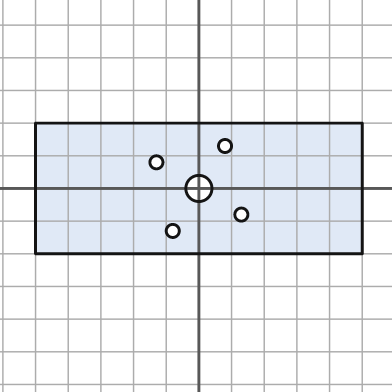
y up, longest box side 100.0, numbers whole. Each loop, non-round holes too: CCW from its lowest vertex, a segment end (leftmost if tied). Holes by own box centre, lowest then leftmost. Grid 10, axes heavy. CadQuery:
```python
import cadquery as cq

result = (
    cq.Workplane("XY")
    .moveTo(-50.0, -20.0)
    .lineTo(50.0, -20.0)
    .lineTo(50.0, 20.0)
    .lineTo(-50.0, 20.0)
    .close()
    .moveTo(-8.0, -13.0)
    .circle(2.0)
    .moveTo(13.0, -8.0)
    .circle(2.0)
    .moveTo(0.0, 0.0)
    .circle(4.0)
    .moveTo(-13.0, 8.0)
    .circle(2.0)
    .moveTo(8.0, 13.0)
    .circle(2.0)
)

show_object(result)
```